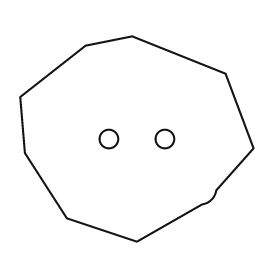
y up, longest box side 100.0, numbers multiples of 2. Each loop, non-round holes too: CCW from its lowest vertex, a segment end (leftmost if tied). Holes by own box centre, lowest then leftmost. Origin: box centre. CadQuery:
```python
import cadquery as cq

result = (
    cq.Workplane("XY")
    .moveTo(0.0, -44.0)
    .lineTo(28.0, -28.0)
    .threePointArc((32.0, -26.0), (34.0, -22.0))
    .lineTo(50.0, -4.0)
    .lineTo(38.0, 28.0)
    .lineTo(-2.0, 44.0)
    .lineTo(-22.0, 40.0)
    .lineTo(-50.0, 18.0)
    .lineTo(-48.0, -6.0)
    .lineTo(-30.0, -34.0)
    .close()
    .moveTo(-12.0, 0.0)
    .circle(4.0)
    .moveTo(12.0, 0.0)
    .circle(4.0)
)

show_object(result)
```